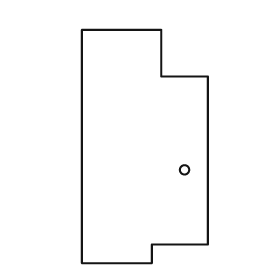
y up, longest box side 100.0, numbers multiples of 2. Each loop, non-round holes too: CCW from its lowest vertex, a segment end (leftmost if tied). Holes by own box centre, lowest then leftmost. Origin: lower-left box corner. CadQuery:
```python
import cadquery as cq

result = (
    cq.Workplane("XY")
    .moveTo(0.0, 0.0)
    .lineTo(30.0, 0.0)
    .lineTo(30.0, 8.0)
    .lineTo(54.0, 8.0)
    .lineTo(54.0, 80.0)
    .lineTo(34.0, 80.0)
    .lineTo(34.0, 100.0)
    .lineTo(0.0, 100.0)
    .close()
    .moveTo(44.0, 40.0)
    .circle(2.0)
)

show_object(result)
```